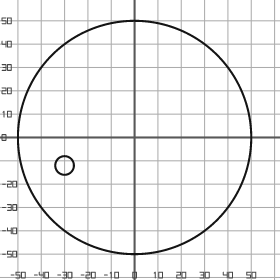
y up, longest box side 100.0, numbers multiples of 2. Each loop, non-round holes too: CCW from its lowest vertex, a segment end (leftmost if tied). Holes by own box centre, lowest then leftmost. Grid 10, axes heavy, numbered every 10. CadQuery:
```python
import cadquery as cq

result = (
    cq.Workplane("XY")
    .moveTo(0.0, 0.0)
    .circle(50.0)
    .moveTo(-30.0, -12.0)
    .circle(4.0)
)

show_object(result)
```